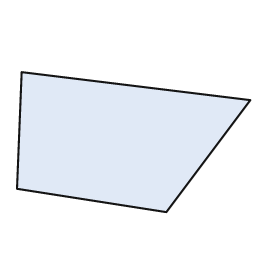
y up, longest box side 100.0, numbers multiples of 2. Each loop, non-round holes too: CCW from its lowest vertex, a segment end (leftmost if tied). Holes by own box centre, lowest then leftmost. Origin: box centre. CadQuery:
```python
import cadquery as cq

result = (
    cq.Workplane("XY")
    .moveTo(14.0, -30.0)
    .lineTo(50.0, 18.0)
    .lineTo(-48.0, 30.0)
    .lineTo(-50.0, -20.0)
    .close()
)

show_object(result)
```